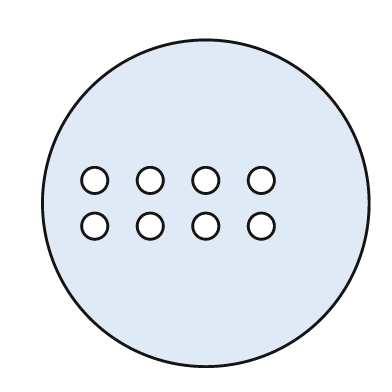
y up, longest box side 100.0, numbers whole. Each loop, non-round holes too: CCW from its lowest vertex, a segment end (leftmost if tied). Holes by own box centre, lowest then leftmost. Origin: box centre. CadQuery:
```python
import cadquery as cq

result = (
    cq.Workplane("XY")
    .moveTo(0.0, 0.0)
    .circle(50.0)
    .moveTo(-34.0, -7.0)
    .circle(4.0)
    .moveTo(-17.0, -7.0)
    .circle(4.0)
    .moveTo(0.0, -7.0)
    .circle(4.0)
    .moveTo(17.0, -7.0)
    .circle(4.0)
    .moveTo(-34.0, 7.0)
    .circle(4.0)
    .moveTo(-17.0, 7.0)
    .circle(4.0)
    .moveTo(0.0, 7.0)
    .circle(4.0)
    .moveTo(17.0, 7.0)
    .circle(4.0)
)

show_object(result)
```